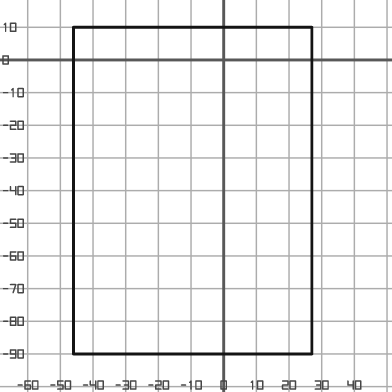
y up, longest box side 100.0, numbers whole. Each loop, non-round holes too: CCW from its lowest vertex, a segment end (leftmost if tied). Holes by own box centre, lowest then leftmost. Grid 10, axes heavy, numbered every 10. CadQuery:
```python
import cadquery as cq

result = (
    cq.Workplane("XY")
    .moveTo(-46.0, -90.0)
    .lineTo(27.0, -90.0)
    .lineTo(27.0, 10.0)
    .lineTo(-46.0, 10.0)
    .close()
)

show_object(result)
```